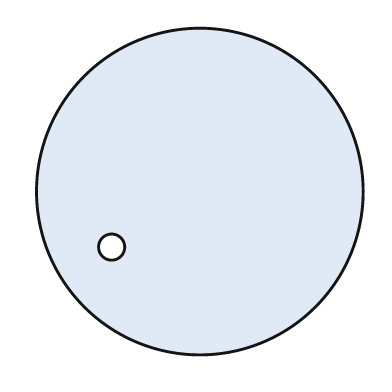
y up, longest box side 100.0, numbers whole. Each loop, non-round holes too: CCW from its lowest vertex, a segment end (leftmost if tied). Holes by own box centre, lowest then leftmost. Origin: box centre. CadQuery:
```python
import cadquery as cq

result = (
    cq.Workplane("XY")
    .moveTo(0.0, 0.0)
    .circle(50.0)
    .moveTo(-27.0, -17.0)
    .circle(4.0)
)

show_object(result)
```